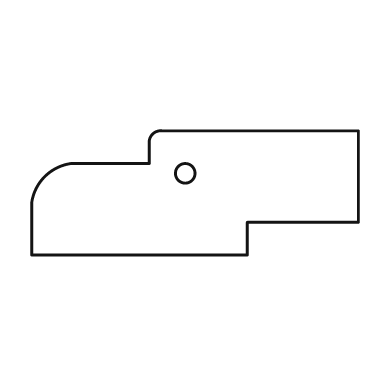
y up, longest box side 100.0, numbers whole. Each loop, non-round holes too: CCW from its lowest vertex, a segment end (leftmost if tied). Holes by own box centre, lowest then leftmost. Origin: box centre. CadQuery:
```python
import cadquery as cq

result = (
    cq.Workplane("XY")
    .moveTo(-50.0, -19.0)
    .lineTo(16.0, -19.0)
    .lineTo(16.0, -9.0)
    .lineTo(50.0, -9.0)
    .lineTo(50.0, 19.0)
    .lineTo(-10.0, 19.0)
    .threePointArc((-13.0, 18.0), (-14.0, 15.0))
    .lineTo(-14.0, 9.0)
    .lineTo(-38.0, 9.0)
    .threePointArc((-46.0, 5.0), (-50.0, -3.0))
    .close()
    .moveTo(-3.0, 6.0)
    .circle(3.0)
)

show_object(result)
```